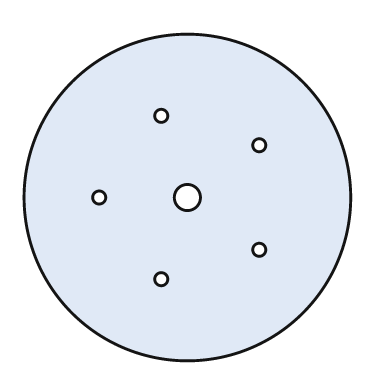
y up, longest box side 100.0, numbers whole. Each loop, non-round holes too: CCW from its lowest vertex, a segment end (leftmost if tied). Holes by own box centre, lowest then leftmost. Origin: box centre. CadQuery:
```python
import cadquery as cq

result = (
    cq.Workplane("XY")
    .moveTo(0.0, 0.0)
    .circle(50.0)
    .moveTo(-8.0, -25.0)
    .circle(2.0)
    .moveTo(22.0, -16.0)
    .circle(2.0)
    .moveTo(-27.0, 0.0)
    .circle(2.0)
    .moveTo(0.0, 0.0)
    .circle(4.0)
    .moveTo(22.0, 16.0)
    .circle(2.0)
    .moveTo(-8.0, 25.0)
    .circle(2.0)
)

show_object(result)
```